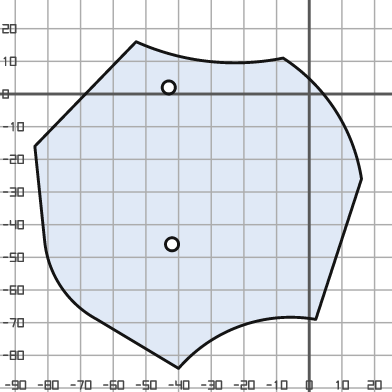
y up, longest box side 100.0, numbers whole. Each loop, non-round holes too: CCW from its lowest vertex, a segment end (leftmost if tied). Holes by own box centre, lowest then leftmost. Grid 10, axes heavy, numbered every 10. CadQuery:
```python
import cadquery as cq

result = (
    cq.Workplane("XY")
    .moveTo(-40.0, -84.0)
    .threePointArc((-21.0, -71.0), (2.0, -69.0))
    .lineTo(16.0, -26.0)
    .threePointArc((8.0, -5.0), (-8.0, 11.0))
    .threePointArc((-31.0, 10.0), (-53.0, 16.0))
    .lineTo(-84.0, -16.0)
    .lineTo(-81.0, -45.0)
    .threePointArc((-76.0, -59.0), (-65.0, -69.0))
    .close()
    .moveTo(-42.0, -46.0)
    .circle(2.0)
    .moveTo(-43.0, 2.0)
    .circle(2.0)
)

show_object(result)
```